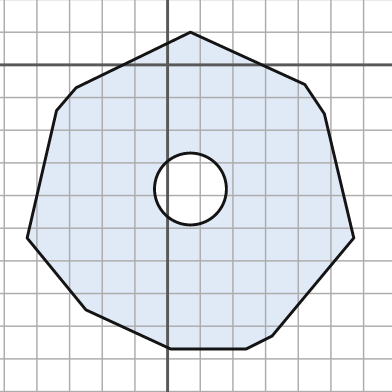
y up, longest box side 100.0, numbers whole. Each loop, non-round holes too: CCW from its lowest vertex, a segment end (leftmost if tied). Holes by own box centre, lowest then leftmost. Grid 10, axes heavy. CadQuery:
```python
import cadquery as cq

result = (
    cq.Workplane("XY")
    .moveTo(1.0, -87.0)
    .lineTo(24.0, -87.0)
    .lineTo(32.0, -83.0)
    .lineTo(57.0, -53.0)
    .lineTo(48.0, -15.0)
    .lineTo(42.0, -6.0)
    .lineTo(7.0, 10.0)
    .lineTo(-28.0, -7.0)
    .lineTo(-34.0, -14.0)
    .lineTo(-43.0, -53.0)
    .lineTo(-25.0, -75.0)
    .close()
    .moveTo(7.0, -38.0)
    .circle(11.0)
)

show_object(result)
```